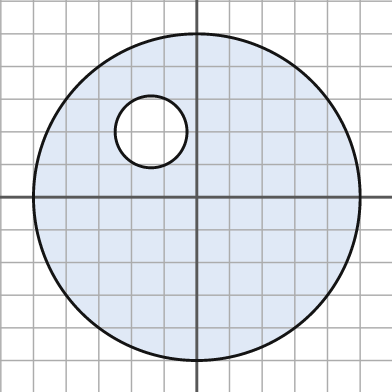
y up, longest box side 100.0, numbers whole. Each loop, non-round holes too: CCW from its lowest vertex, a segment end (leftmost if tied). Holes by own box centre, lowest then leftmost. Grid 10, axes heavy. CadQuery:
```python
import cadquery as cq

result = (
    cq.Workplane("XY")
    .moveTo(0.0, 0.0)
    .circle(50.0)
    .moveTo(-14.0, 20.0)
    .circle(11.0)
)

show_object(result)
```